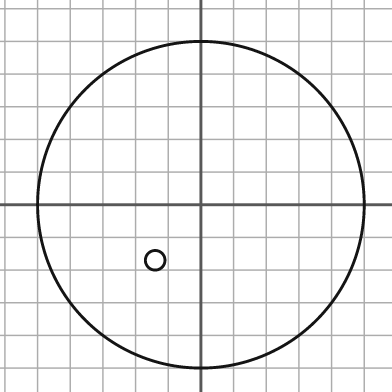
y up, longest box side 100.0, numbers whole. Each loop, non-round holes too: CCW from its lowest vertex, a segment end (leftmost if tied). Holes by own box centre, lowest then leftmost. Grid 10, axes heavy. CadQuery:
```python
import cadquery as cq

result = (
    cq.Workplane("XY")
    .moveTo(0.0, 0.0)
    .circle(50.0)
    .moveTo(-14.0, -17.0)
    .circle(3.0)
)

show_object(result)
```